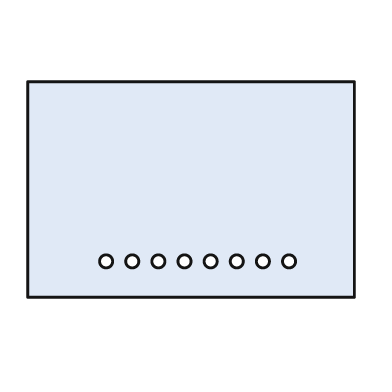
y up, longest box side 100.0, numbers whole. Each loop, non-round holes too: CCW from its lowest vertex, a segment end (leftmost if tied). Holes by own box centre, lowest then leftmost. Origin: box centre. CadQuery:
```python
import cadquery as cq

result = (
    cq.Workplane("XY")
    .moveTo(-50.0, -33.0)
    .lineTo(50.0, -33.0)
    .lineTo(50.0, 33.0)
    .lineTo(-50.0, 33.0)
    .close()
    .moveTo(-26.0, -22.0)
    .circle(2.0)
    .moveTo(-18.0, -22.0)
    .circle(2.0)
    .moveTo(-10.0, -22.0)
    .circle(2.0)
    .moveTo(-2.0, -22.0)
    .circle(2.0)
    .moveTo(6.0, -22.0)
    .circle(2.0)
    .moveTo(14.0, -22.0)
    .circle(2.0)
    .moveTo(22.0, -22.0)
    .circle(2.0)
    .moveTo(30.0, -22.0)
    .circle(2.0)
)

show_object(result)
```